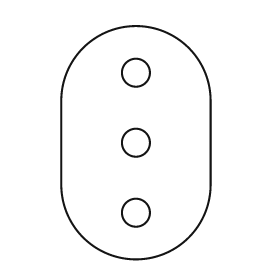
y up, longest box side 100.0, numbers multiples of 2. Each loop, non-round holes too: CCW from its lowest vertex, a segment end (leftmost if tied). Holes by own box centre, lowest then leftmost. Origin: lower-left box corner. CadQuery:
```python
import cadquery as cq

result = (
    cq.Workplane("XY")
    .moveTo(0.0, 32.0)
    .threePointArc((32.0, 0.0), (64.0, 32.0))
    .lineTo(64.0, 68.0)
    .threePointArc((32.0, 100.0), (0.0, 68.0))
    .close()
    .moveTo(32.0, 20.0)
    .circle(6.0)
    .moveTo(32.0, 50.0)
    .circle(6.0)
    .moveTo(32.0, 80.0)
    .circle(6.0)
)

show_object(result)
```